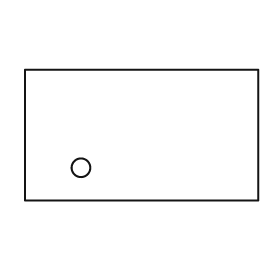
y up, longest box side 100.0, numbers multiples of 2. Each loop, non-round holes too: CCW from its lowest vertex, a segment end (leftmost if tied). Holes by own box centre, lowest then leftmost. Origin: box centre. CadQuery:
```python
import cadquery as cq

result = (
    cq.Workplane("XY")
    .moveTo(-50.0, -28.0)
    .lineTo(50.0, -28.0)
    .lineTo(50.0, 28.0)
    .lineTo(-50.0, 28.0)
    .close()
    .moveTo(-26.0, -14.0)
    .circle(4.0)
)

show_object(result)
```